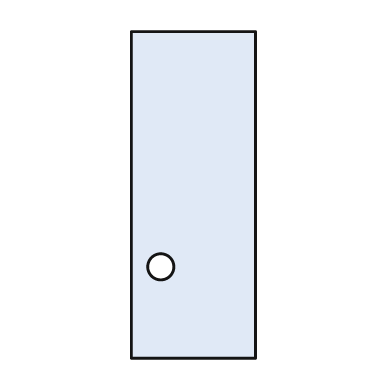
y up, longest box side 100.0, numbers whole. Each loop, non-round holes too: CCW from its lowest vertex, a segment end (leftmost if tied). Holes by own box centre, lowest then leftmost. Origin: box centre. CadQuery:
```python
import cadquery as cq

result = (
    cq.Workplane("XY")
    .moveTo(-19.0, -50.0)
    .lineTo(19.0, -50.0)
    .lineTo(19.0, 50.0)
    .lineTo(-19.0, 50.0)
    .close()
    .moveTo(-10.0, -22.0)
    .circle(4.0)
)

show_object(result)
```